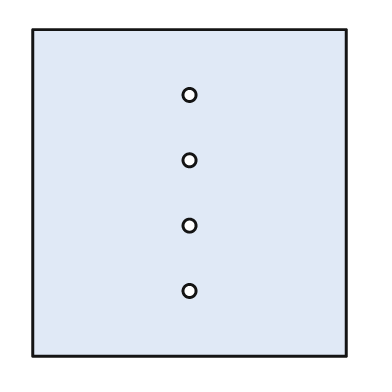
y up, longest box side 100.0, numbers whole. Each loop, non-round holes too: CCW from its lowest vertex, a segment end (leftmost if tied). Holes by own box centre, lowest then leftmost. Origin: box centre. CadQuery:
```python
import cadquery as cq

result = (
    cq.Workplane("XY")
    .moveTo(-48.0, -50.0)
    .lineTo(48.0, -50.0)
    .lineTo(48.0, 50.0)
    .lineTo(-48.0, 50.0)
    .close()
    .moveTo(0.0, -30.0)
    .circle(2.0)
    .moveTo(0.0, -10.0)
    .circle(2.0)
    .moveTo(0.0, 10.0)
    .circle(2.0)
    .moveTo(0.0, 30.0)
    .circle(2.0)
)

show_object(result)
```